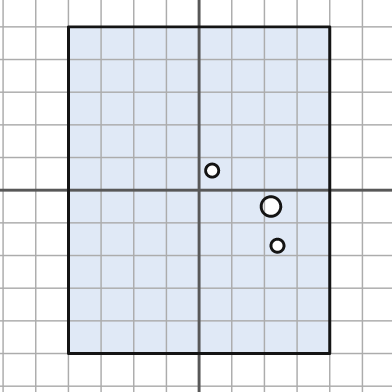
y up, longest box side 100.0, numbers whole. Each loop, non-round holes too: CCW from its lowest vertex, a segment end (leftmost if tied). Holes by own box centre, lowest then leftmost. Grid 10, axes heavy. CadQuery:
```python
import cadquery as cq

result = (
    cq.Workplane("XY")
    .moveTo(-40.0, -50.0)
    .lineTo(40.0, -50.0)
    .lineTo(40.0, 50.0)
    .lineTo(-40.0, 50.0)
    .close()
    .moveTo(24.0, -17.0)
    .circle(2.0)
    .moveTo(22.0, -5.0)
    .circle(3.0)
    .moveTo(4.0, 6.0)
    .circle(2.0)
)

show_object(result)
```